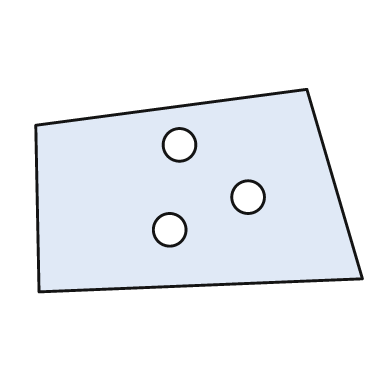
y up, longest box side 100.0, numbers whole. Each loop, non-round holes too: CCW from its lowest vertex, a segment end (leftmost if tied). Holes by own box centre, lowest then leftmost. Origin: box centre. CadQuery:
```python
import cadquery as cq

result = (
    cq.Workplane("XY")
    .moveTo(-49.0, -31.0)
    .lineTo(50.0, -27.0)
    .lineTo(33.0, 31.0)
    .lineTo(-50.0, 20.0)
    .close()
    .moveTo(-9.0, -12.0)
    .circle(5.0)
    .moveTo(15.0, -2.0)
    .circle(5.0)
    .moveTo(-6.0, 14.0)
    .circle(5.0)
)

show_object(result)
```